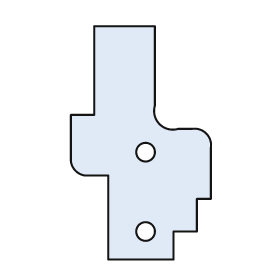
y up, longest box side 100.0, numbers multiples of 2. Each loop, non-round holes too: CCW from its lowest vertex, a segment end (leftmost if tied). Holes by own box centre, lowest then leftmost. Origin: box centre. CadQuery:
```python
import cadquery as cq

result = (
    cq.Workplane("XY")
    .moveTo(-14.0, -50.0)
    .lineTo(14.0, -50.0)
    .lineTo(14.0, -38.0)
    .lineTo(24.0, -38.0)
    .lineTo(24.0, -24.0)
    .lineTo(30.0, -24.0)
    .lineTo(30.0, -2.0)
    .threePointArc((28.0, 4.0), (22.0, 6.0))
    .lineTo(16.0, 6.0)
    .threePointArc((8.0, 8.0), (6.0, 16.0))
    .lineTo(6.0, 50.0)
    .lineTo(-20.0, 50.0)
    .lineTo(-20.0, 12.0)
    .lineTo(-30.0, 12.0)
    .lineTo(-30.0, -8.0)
    .threePointArc((-28.0, -12.0), (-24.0, -14.0))
    .lineTo(-14.0, -14.0)
    .close()
    .moveTo(2.0, -38.0)
    .circle(4.0)
    .moveTo(2.0, -4.0)
    .circle(4.0)
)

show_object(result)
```